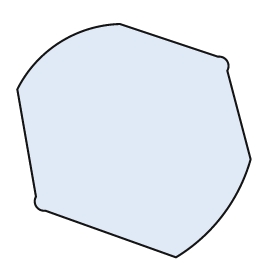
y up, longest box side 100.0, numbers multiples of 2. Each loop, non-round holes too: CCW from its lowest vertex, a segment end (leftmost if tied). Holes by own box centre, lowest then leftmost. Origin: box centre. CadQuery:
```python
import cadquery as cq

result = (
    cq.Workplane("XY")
    .moveTo(18.0, -50.0)
    .threePointArc((38.0, -32.0), (50.0, -8.0))
    .lineTo(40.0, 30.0)
    .threePointArc((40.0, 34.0), (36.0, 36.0))
    .lineTo(-6.0, 50.0)
    .threePointArc((-32.0, 42.0), (-50.0, 22.0))
    .lineTo(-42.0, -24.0)
    .threePointArc((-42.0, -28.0), (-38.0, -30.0))
    .close()
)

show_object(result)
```